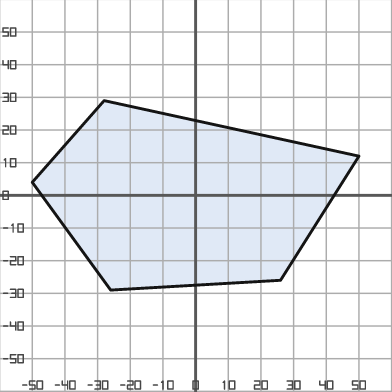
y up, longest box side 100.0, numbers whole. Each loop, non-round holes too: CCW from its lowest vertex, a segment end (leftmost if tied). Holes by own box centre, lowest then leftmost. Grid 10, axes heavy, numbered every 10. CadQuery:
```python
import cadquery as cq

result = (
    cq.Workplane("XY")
    .moveTo(-26.0, -29.0)
    .lineTo(26.0, -26.0)
    .lineTo(50.0, 12.0)
    .lineTo(-28.0, 29.0)
    .lineTo(-50.0, 4.0)
    .close()
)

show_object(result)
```